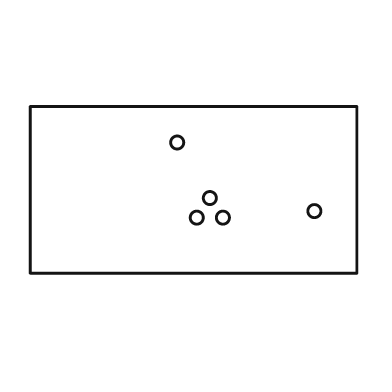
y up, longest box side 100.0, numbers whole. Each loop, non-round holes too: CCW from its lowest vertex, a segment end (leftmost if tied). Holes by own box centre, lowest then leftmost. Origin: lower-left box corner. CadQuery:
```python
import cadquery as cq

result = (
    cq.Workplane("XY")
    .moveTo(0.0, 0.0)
    .lineTo(100.0, 0.0)
    .lineTo(100.0, 51.0)
    .lineTo(0.0, 51.0)
    .close()
    .moveTo(51.0, 17.0)
    .circle(2.0)
    .moveTo(59.0, 17.0)
    .circle(2.0)
    .moveTo(87.0, 19.0)
    .circle(2.0)
    .moveTo(55.0, 23.0)
    .circle(2.0)
    .moveTo(45.0, 40.0)
    .circle(2.0)
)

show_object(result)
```